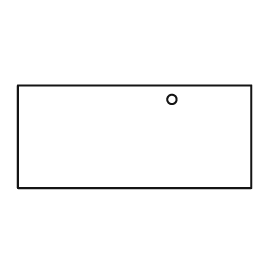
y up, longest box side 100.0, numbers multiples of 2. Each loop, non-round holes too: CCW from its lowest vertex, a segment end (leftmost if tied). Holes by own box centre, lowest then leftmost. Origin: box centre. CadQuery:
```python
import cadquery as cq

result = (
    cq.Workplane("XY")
    .moveTo(-50.0, -22.0)
    .lineTo(50.0, -22.0)
    .lineTo(50.0, 22.0)
    .lineTo(-50.0, 22.0)
    .close()
    .moveTo(16.0, 16.0)
    .circle(2.0)
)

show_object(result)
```